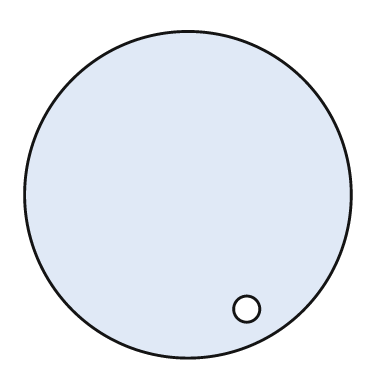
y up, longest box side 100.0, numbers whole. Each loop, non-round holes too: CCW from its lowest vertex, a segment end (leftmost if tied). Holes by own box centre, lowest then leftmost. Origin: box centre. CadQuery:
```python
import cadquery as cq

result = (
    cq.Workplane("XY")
    .moveTo(0.0, 0.0)
    .circle(50.0)
    .moveTo(18.0, -35.0)
    .circle(4.0)
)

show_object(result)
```